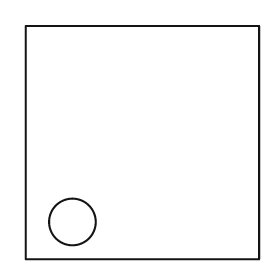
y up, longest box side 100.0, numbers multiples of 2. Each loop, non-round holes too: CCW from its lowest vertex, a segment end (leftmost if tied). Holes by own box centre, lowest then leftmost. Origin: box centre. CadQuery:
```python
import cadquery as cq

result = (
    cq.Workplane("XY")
    .moveTo(-50.0, -50.0)
    .lineTo(50.0, -50.0)
    .lineTo(50.0, 50.0)
    .lineTo(-50.0, 50.0)
    .close()
    .moveTo(-30.0, -34.0)
    .circle(10.0)
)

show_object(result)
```